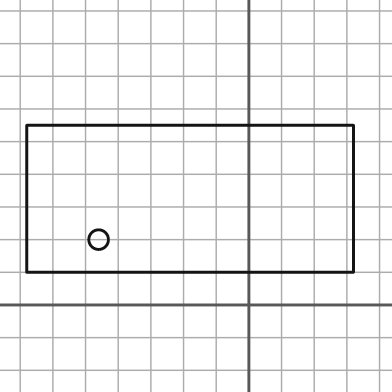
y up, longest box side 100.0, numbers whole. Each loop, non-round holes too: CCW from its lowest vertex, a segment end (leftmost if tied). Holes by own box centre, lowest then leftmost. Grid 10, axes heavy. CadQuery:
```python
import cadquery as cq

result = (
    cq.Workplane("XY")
    .moveTo(-68.0, 10.0)
    .lineTo(32.0, 10.0)
    .lineTo(32.0, 55.0)
    .lineTo(-68.0, 55.0)
    .close()
    .moveTo(-46.0, 20.0)
    .circle(3.0)
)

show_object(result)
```